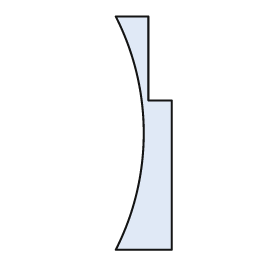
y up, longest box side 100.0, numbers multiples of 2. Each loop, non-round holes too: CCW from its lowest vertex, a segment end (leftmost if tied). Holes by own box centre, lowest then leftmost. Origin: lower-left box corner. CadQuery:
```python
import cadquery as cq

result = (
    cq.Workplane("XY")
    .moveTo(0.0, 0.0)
    .lineTo(24.0, 0.0)
    .lineTo(24.0, 64.0)
    .lineTo(14.0, 64.0)
    .lineTo(14.0, 100.0)
    .lineTo(0.0, 100.0)
    .threePointArc((12.0, 50.0), (0.0, 0.0))
    .close()
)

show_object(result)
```